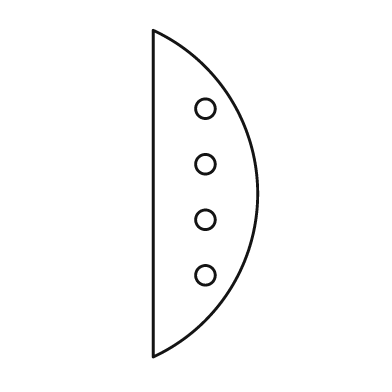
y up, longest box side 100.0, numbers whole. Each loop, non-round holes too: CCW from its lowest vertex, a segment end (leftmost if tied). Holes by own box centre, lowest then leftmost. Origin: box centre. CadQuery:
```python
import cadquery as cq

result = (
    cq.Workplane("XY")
    .moveTo(-16.0, -50.0)
    .threePointArc((16.0, 0.0), (-16.0, 50.0))
    .close()
    .moveTo(0.0, -25.0)
    .circle(3.0)
    .moveTo(0.0, -8.0)
    .circle(3.0)
    .moveTo(0.0, 9.0)
    .circle(3.0)
    .moveTo(0.0, 26.0)
    .circle(3.0)
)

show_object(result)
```